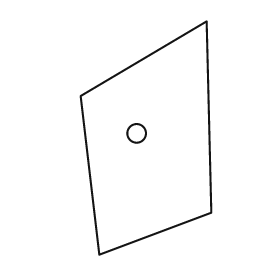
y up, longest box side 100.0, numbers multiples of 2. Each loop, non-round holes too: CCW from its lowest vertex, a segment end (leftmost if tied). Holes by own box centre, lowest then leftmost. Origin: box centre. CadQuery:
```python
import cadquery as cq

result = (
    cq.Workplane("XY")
    .moveTo(-20.0, -50.0)
    .lineTo(28.0, -32.0)
    .lineTo(26.0, 50.0)
    .lineTo(-28.0, 18.0)
    .close()
    .moveTo(-4.0, 2.0)
    .circle(4.0)
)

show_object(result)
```